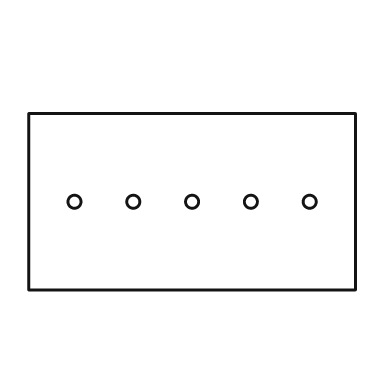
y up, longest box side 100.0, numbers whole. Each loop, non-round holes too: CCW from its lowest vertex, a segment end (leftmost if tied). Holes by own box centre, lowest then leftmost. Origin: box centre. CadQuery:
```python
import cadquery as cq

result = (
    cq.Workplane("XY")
    .moveTo(-50.0, -27.0)
    .lineTo(50.0, -27.0)
    .lineTo(50.0, 27.0)
    .lineTo(-50.0, 27.0)
    .close()
    .moveTo(-36.0, 0.0)
    .circle(2.0)
    .moveTo(-18.0, 0.0)
    .circle(2.0)
    .moveTo(0.0, 0.0)
    .circle(2.0)
    .moveTo(18.0, 0.0)
    .circle(2.0)
    .moveTo(36.0, 0.0)
    .circle(2.0)
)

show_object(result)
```